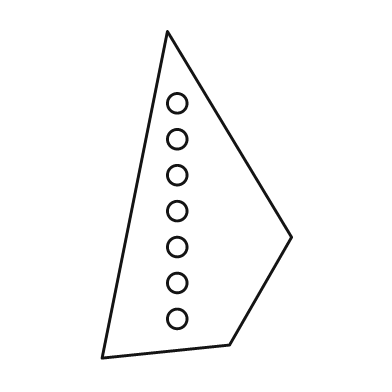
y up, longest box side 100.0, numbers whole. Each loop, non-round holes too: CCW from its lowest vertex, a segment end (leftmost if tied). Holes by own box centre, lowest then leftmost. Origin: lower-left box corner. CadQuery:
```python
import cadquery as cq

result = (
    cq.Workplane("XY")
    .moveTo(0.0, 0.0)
    .lineTo(39.0, 4.0)
    .lineTo(58.0, 37.0)
    .lineTo(20.0, 100.0)
    .close()
    .moveTo(23.0, 12.0)
    .circle(3.0)
    .moveTo(23.0, 23.0)
    .circle(3.0)
    .moveTo(23.0, 34.0)
    .circle(3.0)
    .moveTo(23.0, 45.0)
    .circle(3.0)
    .moveTo(23.0, 56.0)
    .circle(3.0)
    .moveTo(23.0, 67.0)
    .circle(3.0)
    .moveTo(23.0, 78.0)
    .circle(3.0)
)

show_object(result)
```